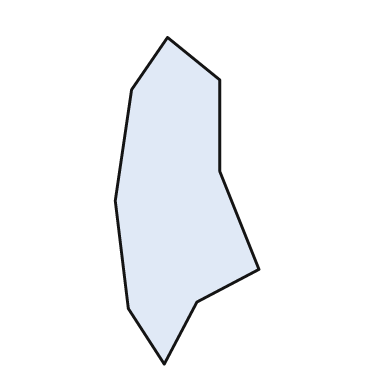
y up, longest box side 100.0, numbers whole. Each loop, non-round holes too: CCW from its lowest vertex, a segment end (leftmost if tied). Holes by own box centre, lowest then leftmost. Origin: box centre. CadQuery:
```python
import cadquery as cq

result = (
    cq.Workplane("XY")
    .moveTo(-7.0, -50.0)
    .lineTo(3.0, -31.0)
    .lineTo(22.0, -21.0)
    .lineTo(10.0, 9.0)
    .lineTo(10.0, 37.0)
    .lineTo(-6.0, 50.0)
    .lineTo(-17.0, 34.0)
    .lineTo(-22.0, 0.0)
    .lineTo(-18.0, -33.0)
    .close()
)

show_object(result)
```